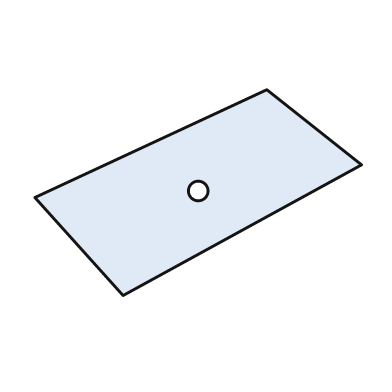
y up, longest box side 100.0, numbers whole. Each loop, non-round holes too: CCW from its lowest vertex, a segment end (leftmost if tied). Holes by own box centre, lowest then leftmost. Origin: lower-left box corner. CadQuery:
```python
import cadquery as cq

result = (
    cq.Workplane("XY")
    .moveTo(27.0, 0.0)
    .lineTo(100.0, 40.0)
    .lineTo(71.0, 63.0)
    .lineTo(0.0, 30.0)
    .close()
    .moveTo(50.0, 32.0)
    .circle(3.0)
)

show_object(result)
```